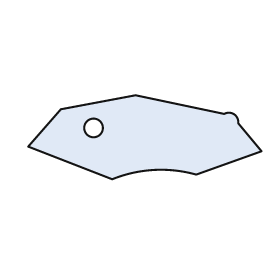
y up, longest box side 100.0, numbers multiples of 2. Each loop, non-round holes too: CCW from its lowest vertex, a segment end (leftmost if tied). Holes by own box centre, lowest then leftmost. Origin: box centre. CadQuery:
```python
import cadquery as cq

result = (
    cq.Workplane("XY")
    .moveTo(-14.0, -18.0)
    .threePointArc((4.0, -14.0), (22.0, -16.0))
    .lineTo(50.0, -6.0)
    .lineTo(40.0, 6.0)
    .threePointArc((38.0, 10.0), (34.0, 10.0))
    .lineTo(-4.0, 18.0)
    .lineTo(-36.0, 12.0)
    .lineTo(-50.0, -4.0)
    .close()
    .moveTo(-22.0, 4.0)
    .circle(4.0)
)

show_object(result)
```